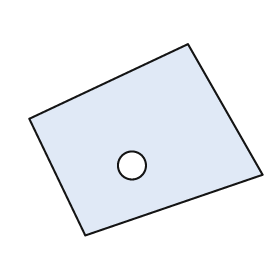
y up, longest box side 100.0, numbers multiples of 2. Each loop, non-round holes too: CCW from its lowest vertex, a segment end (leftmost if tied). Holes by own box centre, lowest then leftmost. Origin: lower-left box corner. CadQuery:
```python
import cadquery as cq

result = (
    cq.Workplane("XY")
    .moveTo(24.0, 0.0)
    .lineTo(100.0, 26.0)
    .lineTo(68.0, 82.0)
    .lineTo(0.0, 50.0)
    .close()
    .moveTo(44.0, 30.0)
    .circle(6.0)
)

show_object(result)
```